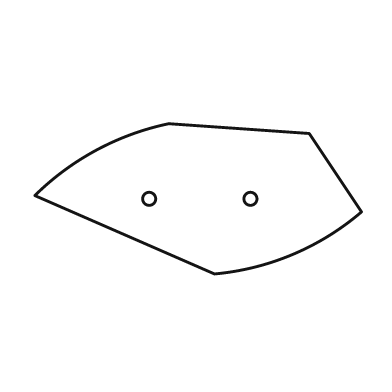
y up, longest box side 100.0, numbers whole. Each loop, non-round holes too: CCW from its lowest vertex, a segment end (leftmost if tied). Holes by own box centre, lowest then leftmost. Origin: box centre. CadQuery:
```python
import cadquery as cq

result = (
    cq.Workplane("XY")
    .moveTo(5.0, -23.0)
    .threePointArc((29.0, -17.0), (50.0, -4.0))
    .lineTo(34.0, 20.0)
    .lineTo(-9.0, 23.0)
    .threePointArc((-31.0, 15.0), (-50.0, 1.0))
    .close()
    .moveTo(-15.0, 0.0)
    .circle(2.0)
    .moveTo(16.0, 0.0)
    .circle(2.0)
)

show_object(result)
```